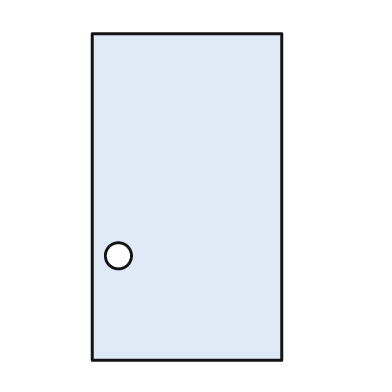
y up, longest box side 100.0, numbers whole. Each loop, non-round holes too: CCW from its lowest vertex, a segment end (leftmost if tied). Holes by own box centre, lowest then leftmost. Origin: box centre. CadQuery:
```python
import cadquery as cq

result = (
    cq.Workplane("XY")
    .moveTo(-29.0, -50.0)
    .lineTo(29.0, -50.0)
    .lineTo(29.0, 50.0)
    .lineTo(-29.0, 50.0)
    .close()
    .moveTo(-21.0, -18.0)
    .circle(4.0)
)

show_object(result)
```